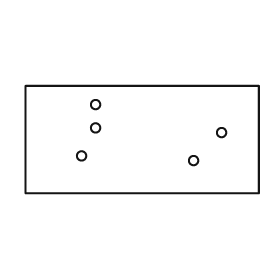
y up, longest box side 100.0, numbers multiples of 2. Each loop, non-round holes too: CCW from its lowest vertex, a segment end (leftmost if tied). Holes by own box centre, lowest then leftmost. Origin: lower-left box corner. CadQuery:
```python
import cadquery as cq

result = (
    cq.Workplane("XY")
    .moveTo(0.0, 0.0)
    .lineTo(100.0, 0.0)
    .lineTo(100.0, 46.0)
    .lineTo(0.0, 46.0)
    .close()
    .moveTo(72.0, 14.0)
    .circle(2.0)
    .moveTo(24.0, 16.0)
    .circle(2.0)
    .moveTo(84.0, 26.0)
    .circle(2.0)
    .moveTo(30.0, 28.0)
    .circle(2.0)
    .moveTo(30.0, 38.0)
    .circle(2.0)
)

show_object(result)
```